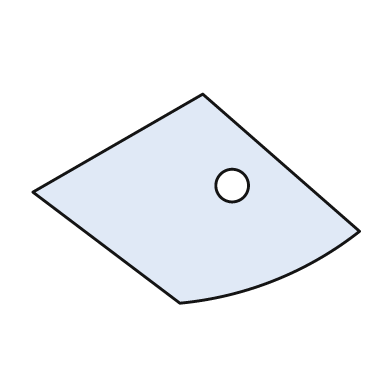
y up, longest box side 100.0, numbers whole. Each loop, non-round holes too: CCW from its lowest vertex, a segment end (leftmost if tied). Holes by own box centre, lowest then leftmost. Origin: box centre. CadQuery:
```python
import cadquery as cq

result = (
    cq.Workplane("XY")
    .moveTo(-5.0, -32.0)
    .threePointArc((24.0, -25.0), (50.0, -10.0))
    .lineTo(2.0, 32.0)
    .lineTo(-50.0, 2.0)
    .close()
    .moveTo(11.0, 4.0)
    .circle(5.0)
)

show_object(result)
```